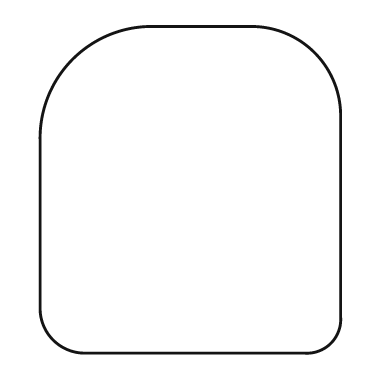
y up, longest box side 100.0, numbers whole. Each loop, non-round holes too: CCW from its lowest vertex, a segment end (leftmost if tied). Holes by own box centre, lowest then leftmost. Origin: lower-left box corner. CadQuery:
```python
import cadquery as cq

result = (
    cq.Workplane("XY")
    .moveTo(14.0, 0.0)
    .lineTo(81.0, 0.0)
    .threePointArc((89.0, 3.0), (92.0, 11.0))
    .lineTo(92.0, 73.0)
    .threePointArc((84.0, 92.0), (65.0, 100.0))
    .lineTo(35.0, 100.0)
    .threePointArc((10.0, 90.0), (0.0, 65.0))
    .lineTo(0.0, 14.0)
    .threePointArc((4.0, 4.0), (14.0, 0.0))
    .close()
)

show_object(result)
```